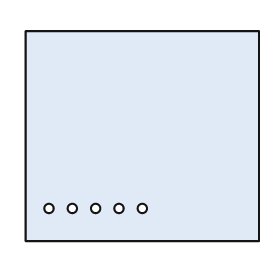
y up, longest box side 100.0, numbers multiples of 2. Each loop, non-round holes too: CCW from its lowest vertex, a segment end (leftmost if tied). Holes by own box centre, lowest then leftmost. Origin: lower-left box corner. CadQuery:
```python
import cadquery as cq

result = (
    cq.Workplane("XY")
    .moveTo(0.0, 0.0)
    .lineTo(100.0, 0.0)
    .lineTo(100.0, 90.0)
    .lineTo(0.0, 90.0)
    .close()
    .moveTo(10.0, 14.0)
    .circle(2.0)
    .moveTo(20.0, 14.0)
    .circle(2.0)
    .moveTo(30.0, 14.0)
    .circle(2.0)
    .moveTo(40.0, 14.0)
    .circle(2.0)
    .moveTo(50.0, 14.0)
    .circle(2.0)
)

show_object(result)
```